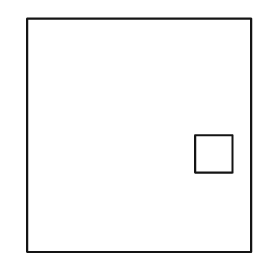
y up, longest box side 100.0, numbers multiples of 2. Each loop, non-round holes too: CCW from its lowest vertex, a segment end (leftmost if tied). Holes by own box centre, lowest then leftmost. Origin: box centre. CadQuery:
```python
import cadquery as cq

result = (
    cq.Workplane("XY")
    .moveTo(-48.0, -50.0)
    .lineTo(48.0, -50.0)
    .lineTo(48.0, 50.0)
    .lineTo(-48.0, 50.0)
    .close()
    .moveTo(24.0, -16.0)
    .lineTo(40.0, -16.0)
    .lineTo(40.0, 0.0)
    .lineTo(24.0, 0.0)
    .close()
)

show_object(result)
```